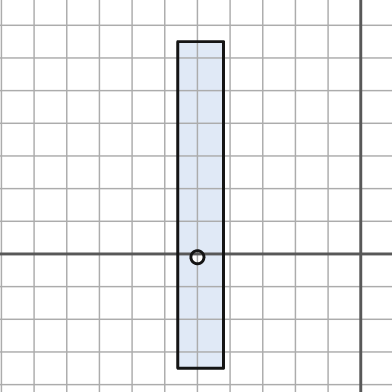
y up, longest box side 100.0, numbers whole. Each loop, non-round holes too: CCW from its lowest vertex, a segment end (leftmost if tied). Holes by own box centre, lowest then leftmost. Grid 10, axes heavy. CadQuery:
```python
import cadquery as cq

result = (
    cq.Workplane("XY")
    .moveTo(-56.0, -35.0)
    .lineTo(-42.0, -35.0)
    .lineTo(-42.0, 65.0)
    .lineTo(-56.0, 65.0)
    .close()
    .moveTo(-50.0, -1.0)
    .circle(2.0)
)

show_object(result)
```